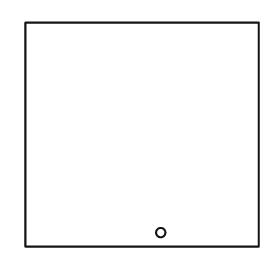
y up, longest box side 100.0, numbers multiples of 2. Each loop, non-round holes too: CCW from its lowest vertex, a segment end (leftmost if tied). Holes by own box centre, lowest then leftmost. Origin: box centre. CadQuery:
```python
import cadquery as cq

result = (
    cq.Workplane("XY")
    .moveTo(-50.0, -48.0)
    .lineTo(50.0, -48.0)
    .lineTo(50.0, 48.0)
    .lineTo(-50.0, 48.0)
    .close()
    .moveTo(8.0, -42.0)
    .circle(2.0)
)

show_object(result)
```